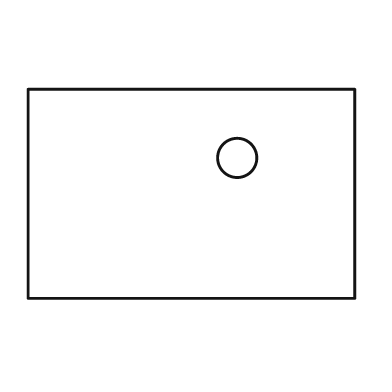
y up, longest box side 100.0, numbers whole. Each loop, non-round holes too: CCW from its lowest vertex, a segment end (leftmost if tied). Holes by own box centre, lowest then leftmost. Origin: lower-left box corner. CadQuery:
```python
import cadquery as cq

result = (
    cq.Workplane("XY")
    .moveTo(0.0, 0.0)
    .lineTo(100.0, 0.0)
    .lineTo(100.0, 64.0)
    .lineTo(0.0, 64.0)
    .close()
    .moveTo(64.0, 43.0)
    .circle(6.0)
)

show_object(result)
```